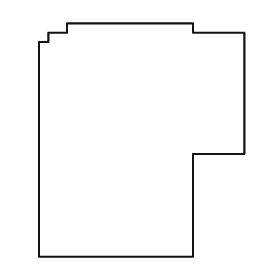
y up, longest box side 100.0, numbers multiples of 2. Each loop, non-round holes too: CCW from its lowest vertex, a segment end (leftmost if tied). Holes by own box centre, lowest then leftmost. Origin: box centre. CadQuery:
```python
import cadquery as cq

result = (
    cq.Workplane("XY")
    .moveTo(-44.0, -50.0)
    .lineTo(22.0, -50.0)
    .lineTo(22.0, -6.0)
    .lineTo(44.0, -6.0)
    .lineTo(44.0, 46.0)
    .lineTo(22.0, 46.0)
    .lineTo(22.0, 50.0)
    .lineTo(-32.0, 50.0)
    .lineTo(-32.0, 46.0)
    .lineTo(-40.0, 46.0)
    .lineTo(-40.0, 42.0)
    .lineTo(-44.0, 42.0)
    .close()
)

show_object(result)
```